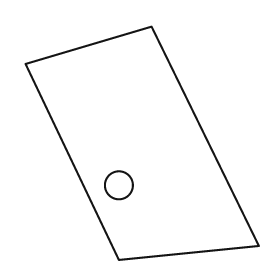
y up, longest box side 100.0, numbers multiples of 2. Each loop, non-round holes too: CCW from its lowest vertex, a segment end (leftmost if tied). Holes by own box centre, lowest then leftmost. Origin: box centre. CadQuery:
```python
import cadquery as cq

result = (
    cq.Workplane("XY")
    .moveTo(-10.0, -50.0)
    .lineTo(50.0, -44.0)
    .lineTo(4.0, 50.0)
    .lineTo(-50.0, 34.0)
    .close()
    .moveTo(-10.0, -18.0)
    .circle(6.0)
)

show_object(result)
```